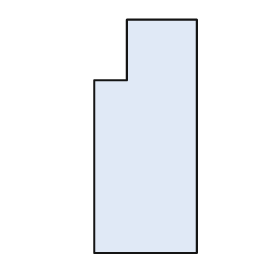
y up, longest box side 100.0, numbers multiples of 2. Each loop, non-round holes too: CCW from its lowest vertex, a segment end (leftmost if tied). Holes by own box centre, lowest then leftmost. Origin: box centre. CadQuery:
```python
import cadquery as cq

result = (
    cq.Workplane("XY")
    .moveTo(-22.0, -50.0)
    .lineTo(22.0, -50.0)
    .lineTo(22.0, 50.0)
    .lineTo(-8.0, 50.0)
    .lineTo(-8.0, 24.0)
    .lineTo(-22.0, 24.0)
    .close()
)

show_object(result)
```